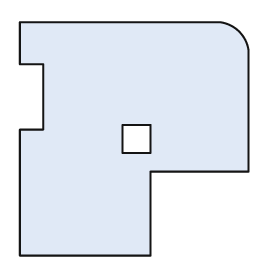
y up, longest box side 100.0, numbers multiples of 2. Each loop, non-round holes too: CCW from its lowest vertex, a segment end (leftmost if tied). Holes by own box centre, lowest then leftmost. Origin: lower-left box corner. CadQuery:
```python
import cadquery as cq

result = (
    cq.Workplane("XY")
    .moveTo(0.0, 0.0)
    .lineTo(56.0, 0.0)
    .lineTo(56.0, 36.0)
    .lineTo(98.0, 36.0)
    .lineTo(98.0, 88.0)
    .threePointArc((94.0, 96.0), (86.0, 100.0))
    .lineTo(0.0, 100.0)
    .lineTo(0.0, 82.0)
    .lineTo(10.0, 82.0)
    .lineTo(10.0, 54.0)
    .lineTo(0.0, 54.0)
    .close()
    .moveTo(44.0, 44.0)
    .lineTo(56.0, 44.0)
    .lineTo(56.0, 56.0)
    .lineTo(44.0, 56.0)
    .close()
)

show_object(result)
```